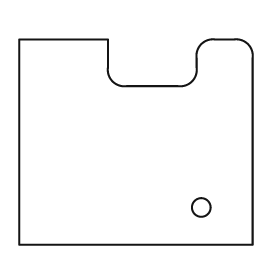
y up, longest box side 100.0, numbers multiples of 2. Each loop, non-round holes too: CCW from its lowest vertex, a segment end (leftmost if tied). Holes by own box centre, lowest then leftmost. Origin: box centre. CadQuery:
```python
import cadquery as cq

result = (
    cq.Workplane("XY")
    .moveTo(-50.0, -44.0)
    .lineTo(50.0, -44.0)
    .lineTo(50.0, 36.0)
    .threePointArc((48.0, 42.0), (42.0, 44.0))
    .lineTo(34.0, 44.0)
    .threePointArc((28.0, 42.0), (26.0, 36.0))
    .lineTo(26.0, 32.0)
    .threePointArc((24.0, 26.0), (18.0, 24.0))
    .lineTo(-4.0, 24.0)
    .threePointArc((-10.0, 26.0), (-12.0, 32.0))
    .lineTo(-12.0, 44.0)
    .lineTo(-50.0, 44.0)
    .close()
    .moveTo(28.0, -28.0)
    .circle(4.0)
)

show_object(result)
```